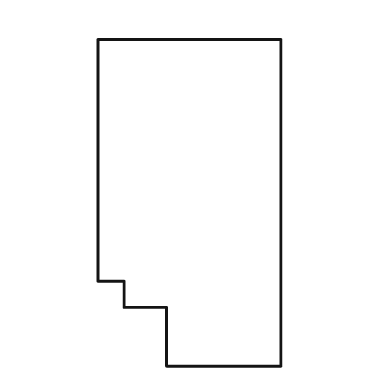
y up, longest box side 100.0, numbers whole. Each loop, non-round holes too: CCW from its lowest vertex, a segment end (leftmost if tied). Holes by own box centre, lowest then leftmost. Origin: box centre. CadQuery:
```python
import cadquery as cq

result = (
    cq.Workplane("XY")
    .moveTo(-7.0, -50.0)
    .lineTo(28.0, -50.0)
    .lineTo(28.0, 50.0)
    .lineTo(-28.0, 50.0)
    .lineTo(-28.0, -24.0)
    .lineTo(-20.0, -24.0)
    .lineTo(-20.0, -32.0)
    .lineTo(-7.0, -32.0)
    .close()
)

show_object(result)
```